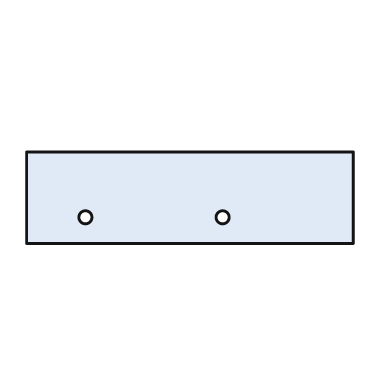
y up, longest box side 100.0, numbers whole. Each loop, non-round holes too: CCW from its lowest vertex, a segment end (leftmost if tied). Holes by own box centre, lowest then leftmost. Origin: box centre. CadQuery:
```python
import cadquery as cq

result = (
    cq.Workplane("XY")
    .moveTo(-50.0, -14.0)
    .lineTo(50.0, -14.0)
    .lineTo(50.0, 14.0)
    .lineTo(-50.0, 14.0)
    .close()
    .moveTo(-32.0, -6.0)
    .circle(2.0)
    .moveTo(10.0, -6.0)
    .circle(2.0)
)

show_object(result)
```